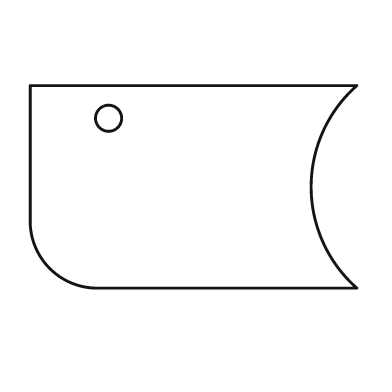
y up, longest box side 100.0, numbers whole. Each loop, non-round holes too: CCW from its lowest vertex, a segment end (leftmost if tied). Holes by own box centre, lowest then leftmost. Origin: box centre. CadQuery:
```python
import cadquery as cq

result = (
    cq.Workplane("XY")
    .moveTo(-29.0, -31.0)
    .lineTo(50.0, -31.0)
    .threePointArc((36.0, 0.0), (50.0, 31.0))
    .lineTo(-50.0, 31.0)
    .lineTo(-50.0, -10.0)
    .threePointArc((-44.0, -25.0), (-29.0, -31.0))
    .close()
    .moveTo(-26.0, 21.0)
    .circle(4.0)
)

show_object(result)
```